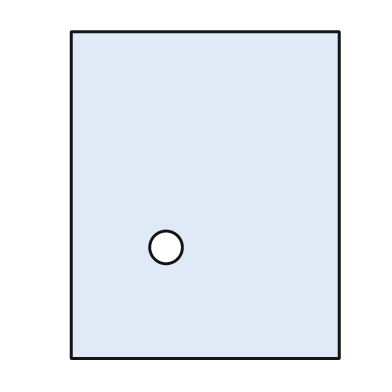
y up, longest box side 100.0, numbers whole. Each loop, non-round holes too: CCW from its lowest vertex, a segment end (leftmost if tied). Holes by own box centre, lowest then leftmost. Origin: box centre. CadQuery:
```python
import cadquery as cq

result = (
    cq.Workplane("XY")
    .moveTo(-41.0, -50.0)
    .lineTo(41.0, -50.0)
    .lineTo(41.0, 50.0)
    .lineTo(-41.0, 50.0)
    .close()
    .moveTo(-12.0, -16.0)
    .circle(5.0)
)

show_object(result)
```